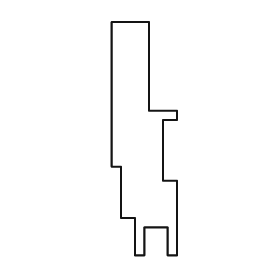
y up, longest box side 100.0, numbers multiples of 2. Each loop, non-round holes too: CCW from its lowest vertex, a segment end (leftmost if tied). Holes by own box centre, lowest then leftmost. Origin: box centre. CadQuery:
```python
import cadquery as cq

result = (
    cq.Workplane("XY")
    .moveTo(-4.0, -50.0)
    .lineTo(0.0, -50.0)
    .lineTo(0.0, -38.0)
    .lineTo(10.0, -38.0)
    .lineTo(10.0, -50.0)
    .lineTo(14.0, -50.0)
    .lineTo(14.0, -18.0)
    .lineTo(8.0, -18.0)
    .lineTo(8.0, 8.0)
    .lineTo(14.0, 8.0)
    .lineTo(14.0, 12.0)
    .lineTo(2.0, 12.0)
    .lineTo(2.0, 50.0)
    .lineTo(-14.0, 50.0)
    .lineTo(-14.0, -12.0)
    .lineTo(-10.0, -12.0)
    .lineTo(-10.0, -34.0)
    .lineTo(-4.0, -34.0)
    .close()
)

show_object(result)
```